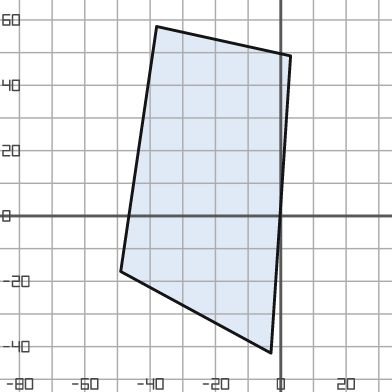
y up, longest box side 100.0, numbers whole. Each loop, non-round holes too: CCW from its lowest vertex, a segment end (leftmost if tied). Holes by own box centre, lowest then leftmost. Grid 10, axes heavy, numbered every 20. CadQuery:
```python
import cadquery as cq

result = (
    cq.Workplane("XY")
    .moveTo(-3.0, -42.0)
    .lineTo(3.0, 49.0)
    .lineTo(-38.0, 58.0)
    .lineTo(-49.0, -17.0)
    .close()
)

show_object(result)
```